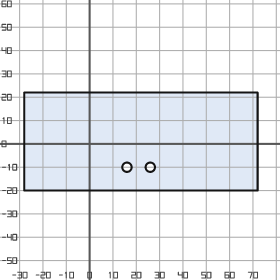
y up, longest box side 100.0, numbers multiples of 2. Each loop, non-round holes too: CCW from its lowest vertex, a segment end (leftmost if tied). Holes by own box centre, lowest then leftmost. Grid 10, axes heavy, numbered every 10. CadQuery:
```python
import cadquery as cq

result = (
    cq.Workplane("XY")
    .moveTo(-28.0, -20.0)
    .lineTo(72.0, -20.0)
    .lineTo(72.0, 22.0)
    .lineTo(-28.0, 22.0)
    .close()
    .moveTo(16.0, -10.0)
    .circle(2.0)
    .moveTo(26.0, -10.0)
    .circle(2.0)
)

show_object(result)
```